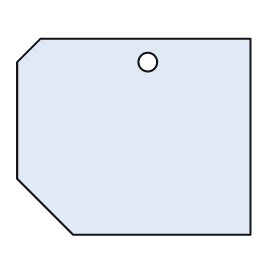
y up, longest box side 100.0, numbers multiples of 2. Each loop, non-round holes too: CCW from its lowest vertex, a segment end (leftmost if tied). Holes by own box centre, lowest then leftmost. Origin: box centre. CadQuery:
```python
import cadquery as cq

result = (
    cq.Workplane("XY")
    .moveTo(-26.0, -42.0)
    .lineTo(50.0, -42.0)
    .lineTo(50.0, 42.0)
    .lineTo(-40.0, 42.0)
    .lineTo(-50.0, 32.0)
    .lineTo(-50.0, -18.0)
    .close()
    .moveTo(6.0, 32.0)
    .circle(4.0)
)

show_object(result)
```